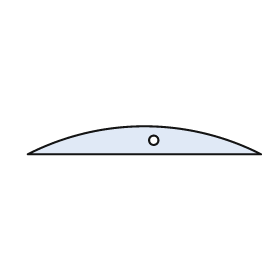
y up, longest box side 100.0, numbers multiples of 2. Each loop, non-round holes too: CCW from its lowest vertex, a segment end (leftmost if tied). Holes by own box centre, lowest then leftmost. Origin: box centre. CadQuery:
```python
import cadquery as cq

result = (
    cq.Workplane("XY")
    .moveTo(-50.0, -6.0)
    .lineTo(50.0, -6.0)
    .threePointArc((0.0, 6.0), (-50.0, -6.0))
    .close()
    .moveTo(4.0, 0.0)
    .circle(2.0)
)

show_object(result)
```